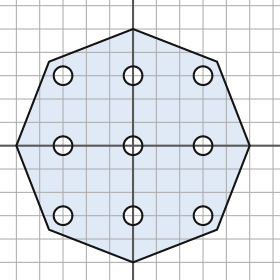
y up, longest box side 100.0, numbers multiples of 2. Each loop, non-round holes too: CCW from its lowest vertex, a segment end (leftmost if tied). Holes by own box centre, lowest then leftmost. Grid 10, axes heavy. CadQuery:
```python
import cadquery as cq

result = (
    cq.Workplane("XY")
    .moveTo(0.0, -50.0)
    .lineTo(36.0, -36.0)
    .lineTo(50.0, 0.0)
    .lineTo(36.0, 36.0)
    .lineTo(0.0, 50.0)
    .lineTo(-36.0, 36.0)
    .lineTo(-50.0, 0.0)
    .lineTo(-36.0, -36.0)
    .close()
    .moveTo(-30.0, -30.0)
    .circle(4.0)
    .moveTo(0.0, -30.0)
    .circle(4.0)
    .moveTo(30.0, -30.0)
    .circle(4.0)
    .moveTo(-30.0, 0.0)
    .circle(4.0)
    .moveTo(0.0, 0.0)
    .circle(4.0)
    .moveTo(30.0, 0.0)
    .circle(4.0)
    .moveTo(-30.0, 30.0)
    .circle(4.0)
    .moveTo(0.0, 30.0)
    .circle(4.0)
    .moveTo(30.0, 30.0)
    .circle(4.0)
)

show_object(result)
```